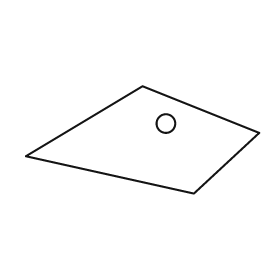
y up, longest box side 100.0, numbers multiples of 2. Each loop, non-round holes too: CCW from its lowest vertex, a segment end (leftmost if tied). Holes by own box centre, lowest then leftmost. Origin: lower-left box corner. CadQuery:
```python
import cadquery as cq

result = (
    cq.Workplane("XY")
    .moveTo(72.0, 0.0)
    .lineTo(100.0, 26.0)
    .lineTo(50.0, 46.0)
    .lineTo(0.0, 16.0)
    .close()
    .moveTo(60.0, 30.0)
    .circle(4.0)
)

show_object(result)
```